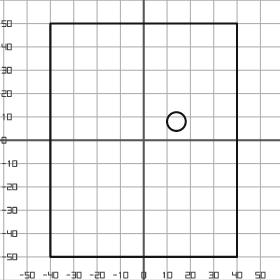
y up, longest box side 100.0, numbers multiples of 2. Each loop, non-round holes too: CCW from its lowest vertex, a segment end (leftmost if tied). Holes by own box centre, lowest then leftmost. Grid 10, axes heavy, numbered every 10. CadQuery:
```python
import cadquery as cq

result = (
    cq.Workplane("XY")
    .moveTo(-40.0, -50.0)
    .lineTo(40.0, -50.0)
    .lineTo(40.0, 50.0)
    .lineTo(-40.0, 50.0)
    .close()
    .moveTo(14.0, 8.0)
    .circle(4.0)
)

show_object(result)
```